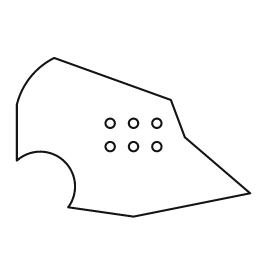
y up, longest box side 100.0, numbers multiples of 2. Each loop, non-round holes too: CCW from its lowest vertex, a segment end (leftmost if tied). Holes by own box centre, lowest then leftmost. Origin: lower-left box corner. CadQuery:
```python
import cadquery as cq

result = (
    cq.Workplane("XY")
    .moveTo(50.0, 0.0)
    .lineTo(100.0, 10.0)
    .lineTo(72.0, 34.0)
    .lineTo(66.0, 50.0)
    .lineTo(16.0, 68.0)
    .threePointArc((6.0, 60.0), (0.0, 48.0))
    .lineTo(0.0, 24.0)
    .threePointArc((20.0, 24.0), (22.0, 4.0))
    .close()
    .moveTo(40.0, 30.0)
    .circle(2.0)
    .moveTo(50.0, 30.0)
    .circle(2.0)
    .moveTo(60.0, 30.0)
    .circle(2.0)
    .moveTo(40.0, 40.0)
    .circle(2.0)
    .moveTo(50.0, 40.0)
    .circle(2.0)
    .moveTo(60.0, 40.0)
    .circle(2.0)
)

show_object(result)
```